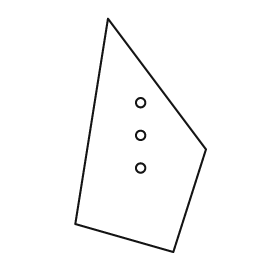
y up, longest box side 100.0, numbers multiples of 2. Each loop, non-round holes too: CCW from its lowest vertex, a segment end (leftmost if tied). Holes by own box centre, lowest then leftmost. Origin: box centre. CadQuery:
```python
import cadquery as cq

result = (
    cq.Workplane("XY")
    .moveTo(14.0, -50.0)
    .lineTo(28.0, -6.0)
    .lineTo(-14.0, 50.0)
    .lineTo(-28.0, -38.0)
    .close()
    .moveTo(0.0, -14.0)
    .circle(2.0)
    .moveTo(0.0, 0.0)
    .circle(2.0)
    .moveTo(0.0, 14.0)
    .circle(2.0)
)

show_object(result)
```